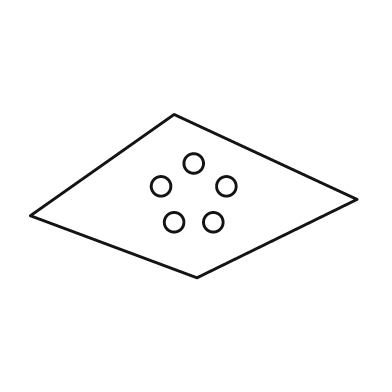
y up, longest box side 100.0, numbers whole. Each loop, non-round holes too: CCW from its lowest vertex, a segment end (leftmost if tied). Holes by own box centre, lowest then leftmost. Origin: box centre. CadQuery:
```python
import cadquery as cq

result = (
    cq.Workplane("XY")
    .moveTo(1.0, -25.0)
    .lineTo(50.0, -1.0)
    .lineTo(-6.0, 25.0)
    .lineTo(-50.0, -6.0)
    .close()
    .moveTo(-6.0, -8.0)
    .circle(3.0)
    .moveTo(6.0, -8.0)
    .circle(3.0)
    .moveTo(-10.0, 3.0)
    .circle(3.0)
    .moveTo(10.0, 3.0)
    .circle(3.0)
    .moveTo(0.0, 10.0)
    .circle(3.0)
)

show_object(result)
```